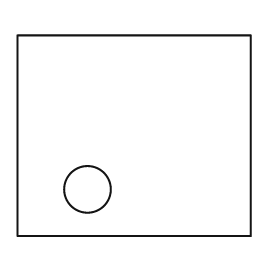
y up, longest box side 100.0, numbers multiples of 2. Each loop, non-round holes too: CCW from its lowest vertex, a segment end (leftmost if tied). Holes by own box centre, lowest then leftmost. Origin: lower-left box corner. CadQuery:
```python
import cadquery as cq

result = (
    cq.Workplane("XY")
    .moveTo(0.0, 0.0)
    .lineTo(100.0, 0.0)
    .lineTo(100.0, 86.0)
    .lineTo(0.0, 86.0)
    .close()
    .moveTo(30.0, 20.0)
    .circle(10.0)
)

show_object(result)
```